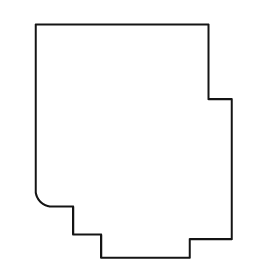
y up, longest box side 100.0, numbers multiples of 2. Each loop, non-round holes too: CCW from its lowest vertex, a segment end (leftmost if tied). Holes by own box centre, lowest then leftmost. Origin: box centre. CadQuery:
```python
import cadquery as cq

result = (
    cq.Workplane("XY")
    .moveTo(-14.0, -50.0)
    .lineTo(24.0, -50.0)
    .lineTo(24.0, -42.0)
    .lineTo(42.0, -42.0)
    .lineTo(42.0, 18.0)
    .lineTo(32.0, 18.0)
    .lineTo(32.0, 50.0)
    .lineTo(-42.0, 50.0)
    .lineTo(-42.0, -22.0)
    .threePointArc((-40.0, -26.0), (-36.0, -28.0))
    .lineTo(-26.0, -28.0)
    .lineTo(-26.0, -40.0)
    .lineTo(-14.0, -40.0)
    .close()
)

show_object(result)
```